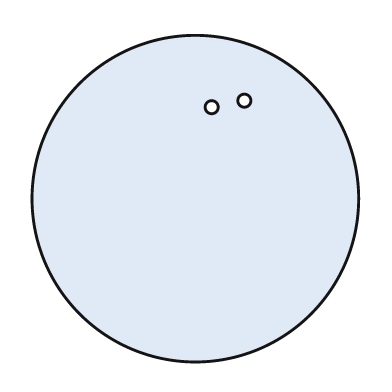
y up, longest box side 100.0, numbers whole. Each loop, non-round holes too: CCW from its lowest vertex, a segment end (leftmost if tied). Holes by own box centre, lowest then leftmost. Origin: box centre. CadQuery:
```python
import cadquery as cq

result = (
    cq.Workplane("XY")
    .moveTo(0.0, 0.0)
    .circle(50.0)
    .moveTo(5.0, 28.0)
    .circle(2.0)
    .moveTo(15.0, 30.0)
    .circle(2.0)
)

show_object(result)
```